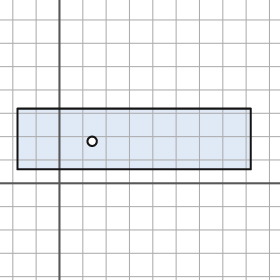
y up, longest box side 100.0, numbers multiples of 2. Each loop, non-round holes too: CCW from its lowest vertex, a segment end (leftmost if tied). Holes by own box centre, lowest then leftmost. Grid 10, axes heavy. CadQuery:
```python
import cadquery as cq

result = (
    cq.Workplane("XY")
    .moveTo(-18.0, 6.0)
    .lineTo(82.0, 6.0)
    .lineTo(82.0, 32.0)
    .lineTo(-18.0, 32.0)
    .close()
    .moveTo(14.0, 18.0)
    .circle(2.0)
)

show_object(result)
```